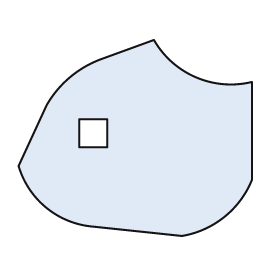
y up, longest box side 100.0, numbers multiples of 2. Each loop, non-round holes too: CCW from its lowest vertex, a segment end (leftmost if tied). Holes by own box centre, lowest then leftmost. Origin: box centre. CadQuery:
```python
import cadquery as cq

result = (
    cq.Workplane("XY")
    .moveTo(20.0, -42.0)
    .threePointArc((38.0, -34.0), (50.0, -18.0))
    .lineTo(50.0, 24.0)
    .threePointArc((26.0, 26.0), (8.0, 42.0))
    .lineTo(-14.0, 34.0)
    .threePointArc((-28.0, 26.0), (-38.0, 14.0))
    .lineTo(-50.0, -12.0)
    .threePointArc((-38.0, -30.0), (-18.0, -38.0))
    .close()
    .moveTo(-24.0, -4.0)
    .lineTo(-12.0, -4.0)
    .lineTo(-12.0, 8.0)
    .lineTo(-24.0, 8.0)
    .close()
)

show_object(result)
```